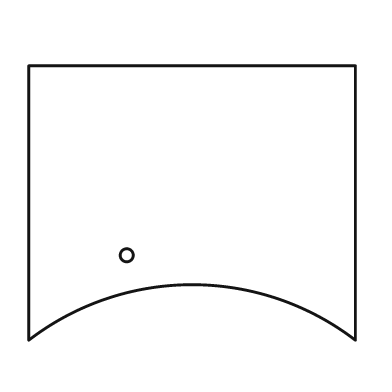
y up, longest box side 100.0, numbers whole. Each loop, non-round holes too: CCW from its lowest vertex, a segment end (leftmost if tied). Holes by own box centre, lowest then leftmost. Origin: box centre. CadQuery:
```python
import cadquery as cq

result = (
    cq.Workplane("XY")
    .moveTo(-50.0, -42.0)
    .threePointArc((0.0, -25.0), (50.0, -42.0))
    .lineTo(50.0, 42.0)
    .lineTo(-50.0, 42.0)
    .close()
    .moveTo(-20.0, -16.0)
    .circle(2.0)
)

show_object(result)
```